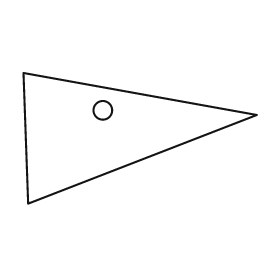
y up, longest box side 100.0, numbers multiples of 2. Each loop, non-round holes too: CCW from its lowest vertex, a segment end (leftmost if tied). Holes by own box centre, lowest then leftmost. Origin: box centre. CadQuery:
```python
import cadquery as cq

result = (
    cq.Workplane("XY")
    .moveTo(-48.0, -28.0)
    .lineTo(50.0, 10.0)
    .lineTo(-50.0, 28.0)
    .close()
    .moveTo(-16.0, 12.0)
    .circle(4.0)
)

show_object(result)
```